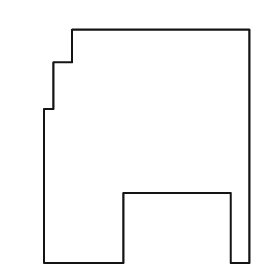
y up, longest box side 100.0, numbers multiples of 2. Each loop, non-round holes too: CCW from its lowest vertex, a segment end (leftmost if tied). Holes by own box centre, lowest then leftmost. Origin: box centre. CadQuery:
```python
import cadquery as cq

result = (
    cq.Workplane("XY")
    .moveTo(-44.0, -50.0)
    .lineTo(-10.0, -50.0)
    .lineTo(-10.0, -20.0)
    .lineTo(36.0, -20.0)
    .lineTo(36.0, -50.0)
    .lineTo(44.0, -50.0)
    .lineTo(44.0, 50.0)
    .lineTo(-32.0, 50.0)
    .lineTo(-32.0, 36.0)
    .lineTo(-40.0, 36.0)
    .lineTo(-40.0, 16.0)
    .lineTo(-44.0, 16.0)
    .close()
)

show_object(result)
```